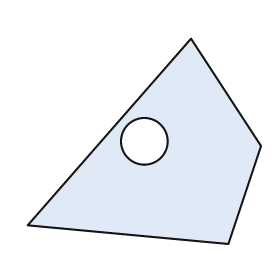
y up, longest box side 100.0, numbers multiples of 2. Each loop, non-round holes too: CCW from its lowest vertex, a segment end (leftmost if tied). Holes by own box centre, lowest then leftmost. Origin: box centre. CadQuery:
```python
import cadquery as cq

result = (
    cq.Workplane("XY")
    .moveTo(36.0, -44.0)
    .lineTo(50.0, -2.0)
    .lineTo(20.0, 44.0)
    .lineTo(-50.0, -36.0)
    .close()
    .moveTo(0.0, 0.0)
    .circle(10.0)
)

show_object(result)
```